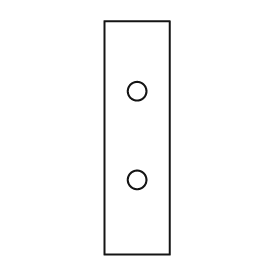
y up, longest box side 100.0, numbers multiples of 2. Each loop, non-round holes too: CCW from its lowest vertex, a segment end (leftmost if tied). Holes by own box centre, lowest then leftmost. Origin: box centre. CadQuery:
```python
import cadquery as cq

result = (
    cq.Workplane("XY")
    .moveTo(-14.0, -50.0)
    .lineTo(14.0, -50.0)
    .lineTo(14.0, 50.0)
    .lineTo(-14.0, 50.0)
    .close()
    .moveTo(0.0, -18.0)
    .circle(4.0)
    .moveTo(0.0, 20.0)
    .circle(4.0)
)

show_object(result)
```